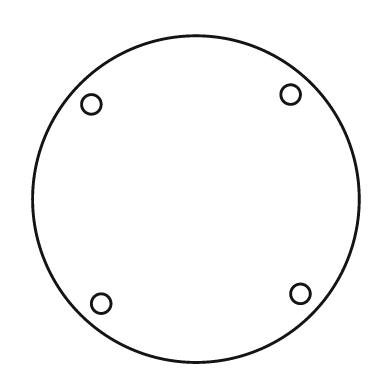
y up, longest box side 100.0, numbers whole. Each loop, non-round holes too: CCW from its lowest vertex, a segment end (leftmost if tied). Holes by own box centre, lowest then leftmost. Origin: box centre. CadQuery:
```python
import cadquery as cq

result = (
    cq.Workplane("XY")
    .moveTo(0.0, 0.0)
    .circle(50.0)
    .moveTo(-29.0, -32.0)
    .circle(3.0)
    .moveTo(32.0, -29.0)
    .circle(3.0)
    .moveTo(-32.0, 29.0)
    .circle(3.0)
    .moveTo(29.0, 32.0)
    .circle(3.0)
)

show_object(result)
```